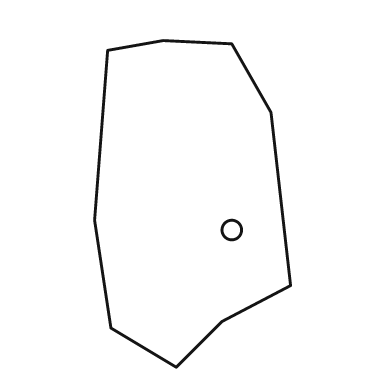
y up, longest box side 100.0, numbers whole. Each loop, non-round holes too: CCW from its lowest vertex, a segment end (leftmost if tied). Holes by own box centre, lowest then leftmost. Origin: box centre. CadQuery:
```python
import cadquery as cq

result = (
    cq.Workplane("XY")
    .moveTo(-5.0, -50.0)
    .lineTo(9.0, -36.0)
    .lineTo(30.0, -25.0)
    .lineTo(24.0, 28.0)
    .lineTo(12.0, 49.0)
    .lineTo(-9.0, 50.0)
    .lineTo(-26.0, 47.0)
    .lineTo(-30.0, -5.0)
    .lineTo(-25.0, -38.0)
    .close()
    .moveTo(12.0, -8.0)
    .circle(3.0)
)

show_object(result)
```